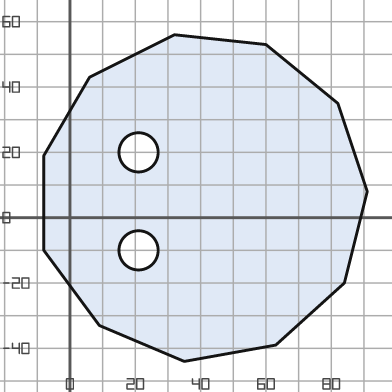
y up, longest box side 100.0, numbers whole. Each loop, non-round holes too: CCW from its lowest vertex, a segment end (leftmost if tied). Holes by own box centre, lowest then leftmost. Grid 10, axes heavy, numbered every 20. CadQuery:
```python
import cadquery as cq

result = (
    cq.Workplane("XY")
    .moveTo(35.0, -44.0)
    .lineTo(63.0, -39.0)
    .lineTo(84.0, -20.0)
    .lineTo(91.0, 8.0)
    .lineTo(82.0, 35.0)
    .lineTo(60.0, 53.0)
    .lineTo(32.0, 56.0)
    .lineTo(6.0, 43.0)
    .lineTo(-8.0, 19.0)
    .lineTo(-8.0, -10.0)
    .lineTo(9.0, -33.0)
    .close()
    .moveTo(21.0, -10.0)
    .circle(6.0)
    .moveTo(21.0, 20.0)
    .circle(6.0)
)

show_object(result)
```